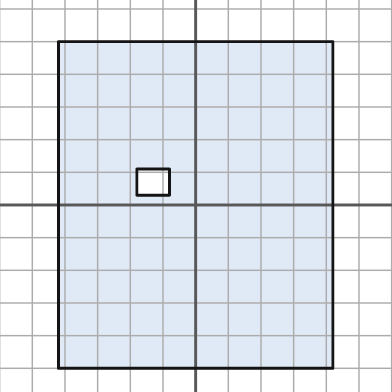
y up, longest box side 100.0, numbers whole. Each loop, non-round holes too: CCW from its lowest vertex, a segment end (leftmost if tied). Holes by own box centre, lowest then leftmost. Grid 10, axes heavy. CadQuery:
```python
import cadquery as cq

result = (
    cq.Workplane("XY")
    .moveTo(-42.0, -50.0)
    .lineTo(42.0, -50.0)
    .lineTo(42.0, 50.0)
    .lineTo(-42.0, 50.0)
    .close()
    .moveTo(-18.0, 3.0)
    .lineTo(-8.0, 3.0)
    .lineTo(-8.0, 11.0)
    .lineTo(-18.0, 11.0)
    .close()
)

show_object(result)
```